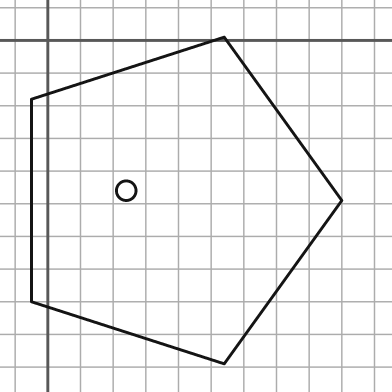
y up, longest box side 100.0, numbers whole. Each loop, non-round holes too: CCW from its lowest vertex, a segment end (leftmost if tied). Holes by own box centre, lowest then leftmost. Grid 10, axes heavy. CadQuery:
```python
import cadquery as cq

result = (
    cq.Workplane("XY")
    .moveTo(54.0, -99.0)
    .lineTo(90.0, -49.0)
    .lineTo(54.0, 1.0)
    .lineTo(-5.0, -18.0)
    .lineTo(-5.0, -80.0)
    .close()
    .moveTo(24.0, -46.0)
    .circle(3.0)
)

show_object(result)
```